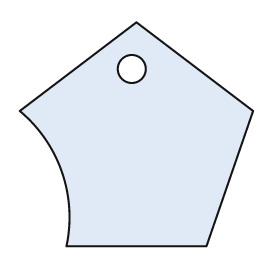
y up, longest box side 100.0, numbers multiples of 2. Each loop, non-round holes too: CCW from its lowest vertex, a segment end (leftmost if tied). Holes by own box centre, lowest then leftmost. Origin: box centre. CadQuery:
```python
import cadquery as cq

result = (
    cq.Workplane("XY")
    .moveTo(-30.0, -48.0)
    .lineTo(30.0, -48.0)
    .lineTo(50.0, 10.0)
    .lineTo(0.0, 48.0)
    .lineTo(-50.0, 10.0)
    .threePointArc((-32.0, -16.0), (-30.0, -48.0))
    .close()
    .moveTo(-2.0, 28.0)
    .circle(6.0)
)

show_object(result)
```